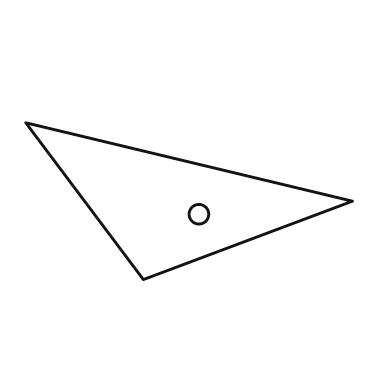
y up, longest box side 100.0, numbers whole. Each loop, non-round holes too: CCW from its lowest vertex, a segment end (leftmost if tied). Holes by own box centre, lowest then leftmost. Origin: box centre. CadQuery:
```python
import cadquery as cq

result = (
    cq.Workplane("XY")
    .moveTo(-14.0, -24.0)
    .lineTo(50.0, 0.0)
    .lineTo(-50.0, 24.0)
    .close()
    .moveTo(3.0, -4.0)
    .circle(3.0)
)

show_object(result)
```